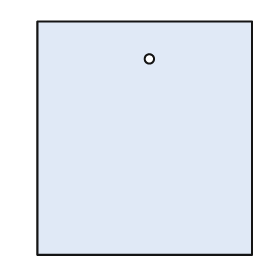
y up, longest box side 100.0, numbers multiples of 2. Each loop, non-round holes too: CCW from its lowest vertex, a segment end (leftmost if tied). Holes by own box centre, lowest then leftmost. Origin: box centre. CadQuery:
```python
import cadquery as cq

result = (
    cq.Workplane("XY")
    .moveTo(-46.0, -50.0)
    .lineTo(46.0, -50.0)
    .lineTo(46.0, 50.0)
    .lineTo(-46.0, 50.0)
    .close()
    .moveTo(2.0, 34.0)
    .circle(2.0)
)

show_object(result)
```